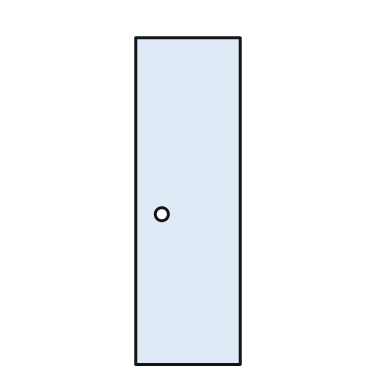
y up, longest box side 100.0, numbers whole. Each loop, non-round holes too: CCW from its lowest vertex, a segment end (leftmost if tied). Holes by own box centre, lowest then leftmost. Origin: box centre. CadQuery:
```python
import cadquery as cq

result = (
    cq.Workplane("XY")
    .moveTo(-16.0, -50.0)
    .lineTo(16.0, -50.0)
    .lineTo(16.0, 50.0)
    .lineTo(-16.0, 50.0)
    .close()
    .moveTo(-8.0, -4.0)
    .circle(2.0)
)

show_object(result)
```